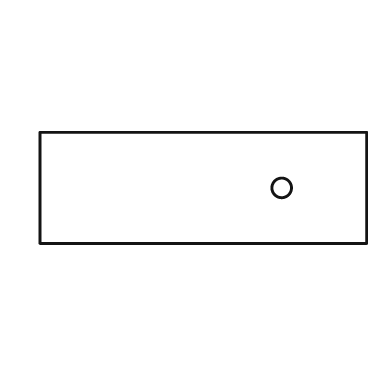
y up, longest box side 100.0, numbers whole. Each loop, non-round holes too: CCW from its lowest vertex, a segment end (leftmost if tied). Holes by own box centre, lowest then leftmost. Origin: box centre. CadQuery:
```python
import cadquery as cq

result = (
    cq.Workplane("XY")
    .moveTo(-50.0, -17.0)
    .lineTo(50.0, -17.0)
    .lineTo(50.0, 17.0)
    .lineTo(-50.0, 17.0)
    .close()
    .moveTo(24.0, 0.0)
    .circle(3.0)
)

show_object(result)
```